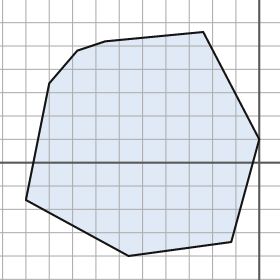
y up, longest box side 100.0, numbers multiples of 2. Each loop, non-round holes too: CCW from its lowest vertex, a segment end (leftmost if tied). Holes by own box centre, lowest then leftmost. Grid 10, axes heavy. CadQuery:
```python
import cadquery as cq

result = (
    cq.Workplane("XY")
    .moveTo(-56.0, -40.0)
    .lineTo(-12.0, -34.0)
    .lineTo(0.0, 10.0)
    .lineTo(-24.0, 56.0)
    .lineTo(-66.0, 52.0)
    .lineTo(-78.0, 48.0)
    .lineTo(-90.0, 34.0)
    .lineTo(-100.0, -16.0)
    .close()
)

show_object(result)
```